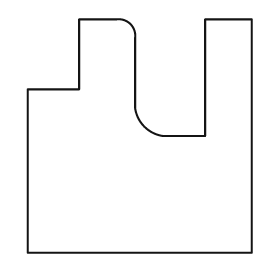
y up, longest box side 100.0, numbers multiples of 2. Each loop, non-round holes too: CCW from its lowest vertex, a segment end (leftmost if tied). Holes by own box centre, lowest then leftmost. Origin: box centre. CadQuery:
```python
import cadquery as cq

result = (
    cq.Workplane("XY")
    .moveTo(-48.0, -50.0)
    .lineTo(48.0, -50.0)
    .lineTo(48.0, 50.0)
    .lineTo(28.0, 50.0)
    .lineTo(28.0, 0.0)
    .lineTo(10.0, 0.0)
    .threePointArc((2.0, 4.0), (-2.0, 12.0))
    .lineTo(-2.0, 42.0)
    .threePointArc((-4.0, 48.0), (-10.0, 50.0))
    .lineTo(-26.0, 50.0)
    .lineTo(-26.0, 20.0)
    .lineTo(-48.0, 20.0)
    .close()
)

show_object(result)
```